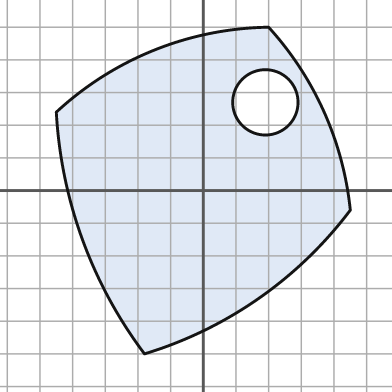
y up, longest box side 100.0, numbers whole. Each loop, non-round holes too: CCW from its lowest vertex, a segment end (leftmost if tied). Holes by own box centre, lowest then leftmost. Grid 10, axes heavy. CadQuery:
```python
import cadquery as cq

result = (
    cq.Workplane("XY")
    .moveTo(-18.0, -50.0)
    .threePointArc((17.0, -33.0), (45.0, -6.0))
    .threePointArc((37.0, 24.0), (20.0, 50.0))
    .threePointArc((-15.0, 43.0), (-45.0, 24.0))
    .threePointArc((-37.0, -15.0), (-18.0, -50.0))
    .close()
    .moveTo(19.0, 27.0)
    .circle(10.0)
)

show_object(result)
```